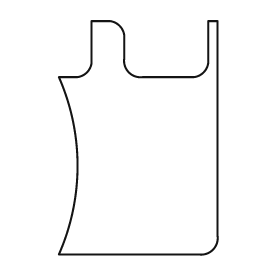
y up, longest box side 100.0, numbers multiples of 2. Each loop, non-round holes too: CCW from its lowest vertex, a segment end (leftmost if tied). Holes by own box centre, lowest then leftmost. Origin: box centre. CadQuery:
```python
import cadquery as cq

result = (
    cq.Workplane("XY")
    .moveTo(-34.0, -50.0)
    .lineTo(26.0, -50.0)
    .threePointArc((32.0, -48.0), (34.0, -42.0))
    .lineTo(34.0, 50.0)
    .lineTo(30.0, 50.0)
    .lineTo(30.0, 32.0)
    .threePointArc((28.0, 28.0), (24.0, 26.0))
    .lineTo(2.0, 26.0)
    .threePointArc((-4.0, 28.0), (-6.0, 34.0))
    .lineTo(-6.0, 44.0)
    .threePointArc((-8.0, 48.0), (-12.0, 50.0))
    .lineTo(-20.0, 50.0)
    .lineTo(-20.0, 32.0)
    .threePointArc((-22.0, 28.0), (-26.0, 26.0))
    .lineTo(-34.0, 26.0)
    .threePointArc((-26.0, -12.0), (-34.0, -50.0))
    .close()
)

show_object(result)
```